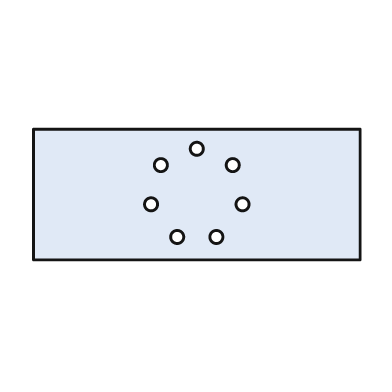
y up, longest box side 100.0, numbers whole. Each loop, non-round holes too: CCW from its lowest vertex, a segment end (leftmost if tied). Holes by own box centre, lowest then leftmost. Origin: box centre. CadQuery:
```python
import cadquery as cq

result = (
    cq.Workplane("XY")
    .moveTo(-50.0, -20.0)
    .lineTo(50.0, -20.0)
    .lineTo(50.0, 20.0)
    .lineTo(-50.0, 20.0)
    .close()
    .moveTo(-6.0, -13.0)
    .circle(2.0)
    .moveTo(6.0, -13.0)
    .circle(2.0)
    .moveTo(-14.0, -3.0)
    .circle(2.0)
    .moveTo(14.0, -3.0)
    .circle(2.0)
    .moveTo(-11.0, 9.0)
    .circle(2.0)
    .moveTo(11.0, 9.0)
    .circle(2.0)
    .moveTo(0.0, 14.0)
    .circle(2.0)
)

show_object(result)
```